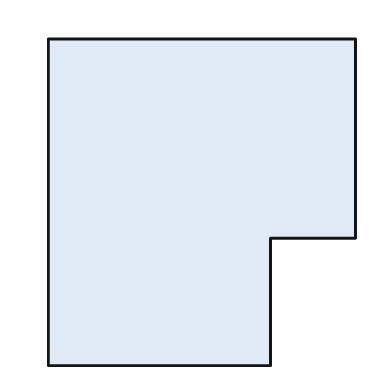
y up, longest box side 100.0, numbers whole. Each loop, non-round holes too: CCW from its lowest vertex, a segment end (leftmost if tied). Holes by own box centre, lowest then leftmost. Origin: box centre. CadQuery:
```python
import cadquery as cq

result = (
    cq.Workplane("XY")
    .moveTo(-47.0, -50.0)
    .lineTo(21.0, -50.0)
    .lineTo(21.0, -11.0)
    .lineTo(47.0, -11.0)
    .lineTo(47.0, 50.0)
    .lineTo(-47.0, 50.0)
    .close()
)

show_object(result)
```